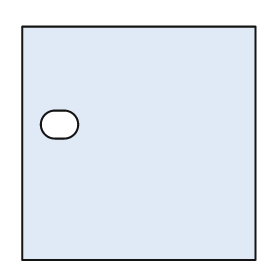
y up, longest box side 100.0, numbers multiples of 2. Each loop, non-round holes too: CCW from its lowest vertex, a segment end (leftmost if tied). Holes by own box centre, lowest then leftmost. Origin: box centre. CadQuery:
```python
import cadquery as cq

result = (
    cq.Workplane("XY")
    .moveTo(-50.0, -50.0)
    .lineTo(50.0, -50.0)
    .lineTo(50.0, 50.0)
    .lineTo(-50.0, 50.0)
    .close()
    .moveTo(-36.0, 2.0)
    .lineTo(-32.0, 2.0)
    .threePointArc((-26.0, 8.0), (-32.0, 14.0))
    .lineTo(-36.0, 14.0)
    .threePointArc((-42.0, 8.0), (-36.0, 2.0))
    .close()
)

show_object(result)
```